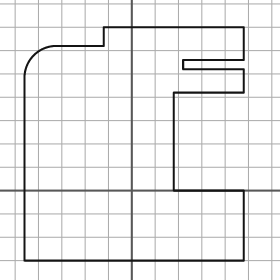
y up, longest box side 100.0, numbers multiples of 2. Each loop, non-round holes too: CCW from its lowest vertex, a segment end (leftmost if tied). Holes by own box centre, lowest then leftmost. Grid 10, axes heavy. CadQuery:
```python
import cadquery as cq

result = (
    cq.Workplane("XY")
    .moveTo(-46.0, -30.0)
    .lineTo(48.0, -30.0)
    .lineTo(48.0, 0.0)
    .lineTo(18.0, 0.0)
    .lineTo(18.0, 42.0)
    .lineTo(48.0, 42.0)
    .lineTo(48.0, 52.0)
    .lineTo(22.0, 52.0)
    .lineTo(22.0, 56.0)
    .lineTo(48.0, 56.0)
    .lineTo(48.0, 70.0)
    .lineTo(-12.0, 70.0)
    .lineTo(-12.0, 62.0)
    .lineTo(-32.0, 62.0)
    .threePointArc((-42.0, 58.0), (-46.0, 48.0))
    .close()
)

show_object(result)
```